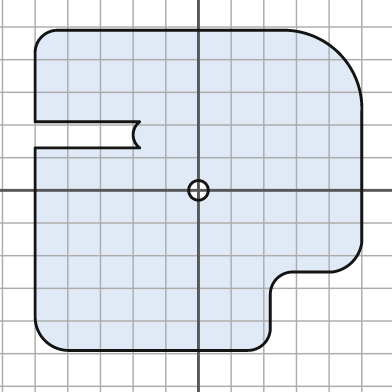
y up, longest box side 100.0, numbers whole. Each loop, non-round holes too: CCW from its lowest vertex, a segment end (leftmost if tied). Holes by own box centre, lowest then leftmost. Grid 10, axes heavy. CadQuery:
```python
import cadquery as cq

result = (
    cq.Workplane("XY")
    .moveTo(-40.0, -49.0)
    .lineTo(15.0, -49.0)
    .threePointArc((20.0, -47.0), (22.0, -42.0))
    .lineTo(22.0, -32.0)
    .threePointArc((24.0, -27.0), (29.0, -25.0))
    .lineTo(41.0, -25.0)
    .threePointArc((47.0, -22.0), (50.0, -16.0))
    .lineTo(50.0, 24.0)
    .threePointArc((43.0, 42.0), (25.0, 49.0))
    .lineTo(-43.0, 49.0)
    .threePointArc((-48.0, 47.0), (-50.0, 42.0))
    .lineTo(-50.0, 21.0)
    .lineTo(-18.0, 21.0)
    .threePointArc((-20.0, 17.0), (-18.0, 13.0))
    .lineTo(-50.0, 13.0)
    .lineTo(-50.0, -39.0)
    .threePointArc((-47.0, -46.0), (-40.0, -49.0))
    .close()
    .moveTo(0.0, 0.0)
    .circle(3.0)
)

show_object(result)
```